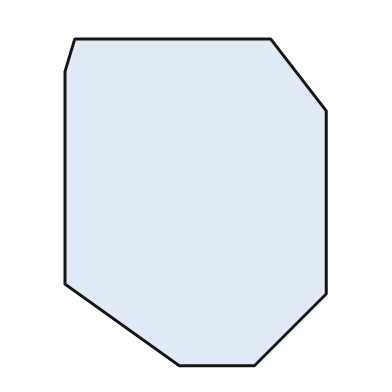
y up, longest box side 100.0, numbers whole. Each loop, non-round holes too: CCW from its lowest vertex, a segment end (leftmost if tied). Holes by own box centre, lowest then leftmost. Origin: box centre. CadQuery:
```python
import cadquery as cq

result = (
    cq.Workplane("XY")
    .moveTo(-5.0, -50.0)
    .lineTo(18.0, -50.0)
    .lineTo(40.0, -28.0)
    .lineTo(40.0, 28.0)
    .lineTo(23.0, 50.0)
    .lineTo(-37.0, 50.0)
    .lineTo(-40.0, 40.0)
    .lineTo(-40.0, -25.0)
    .close()
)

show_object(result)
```